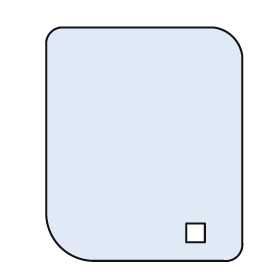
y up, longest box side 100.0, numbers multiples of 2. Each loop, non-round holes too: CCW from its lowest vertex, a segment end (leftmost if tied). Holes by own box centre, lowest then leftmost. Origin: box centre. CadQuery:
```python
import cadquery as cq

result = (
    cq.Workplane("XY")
    .moveTo(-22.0, -50.0)
    .lineTo(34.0, -50.0)
    .threePointArc((40.0, -48.0), (42.0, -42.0))
    .lineTo(42.0, 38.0)
    .threePointArc((38.0, 46.0), (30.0, 50.0))
    .lineTo(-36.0, 50.0)
    .threePointArc((-40.0, 48.0), (-42.0, 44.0))
    .lineTo(-42.0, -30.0)
    .threePointArc((-36.0, -44.0), (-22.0, -50.0))
    .close()
    .moveTo(18.0, -42.0)
    .lineTo(26.0, -42.0)
    .lineTo(26.0, -34.0)
    .lineTo(18.0, -34.0)
    .close()
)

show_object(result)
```